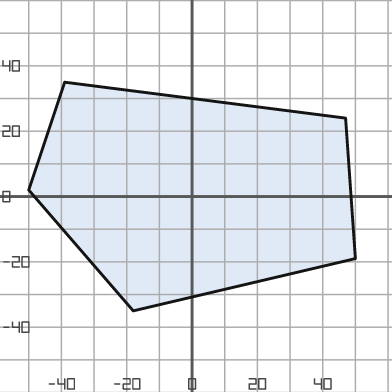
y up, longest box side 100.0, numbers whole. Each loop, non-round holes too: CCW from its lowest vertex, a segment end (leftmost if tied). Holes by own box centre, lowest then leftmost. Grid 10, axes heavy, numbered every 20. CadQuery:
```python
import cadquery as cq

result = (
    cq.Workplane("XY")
    .moveTo(-18.0, -35.0)
    .lineTo(50.0, -19.0)
    .lineTo(47.0, 24.0)
    .lineTo(-39.0, 35.0)
    .lineTo(-50.0, 2.0)
    .close()
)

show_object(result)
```